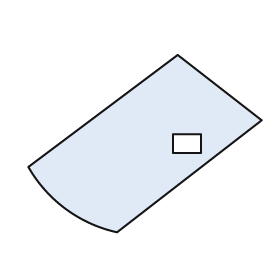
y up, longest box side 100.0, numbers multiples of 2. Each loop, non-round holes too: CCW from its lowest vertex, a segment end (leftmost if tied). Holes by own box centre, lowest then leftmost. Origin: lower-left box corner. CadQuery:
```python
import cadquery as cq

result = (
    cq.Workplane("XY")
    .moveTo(38.0, 0.0)
    .lineTo(100.0, 48.0)
    .lineTo(64.0, 76.0)
    .lineTo(0.0, 28.0)
    .threePointArc((16.0, 10.0), (38.0, 0.0))
    .close()
    .moveTo(62.0, 34.0)
    .lineTo(74.0, 34.0)
    .lineTo(74.0, 42.0)
    .lineTo(62.0, 42.0)
    .close()
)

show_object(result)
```